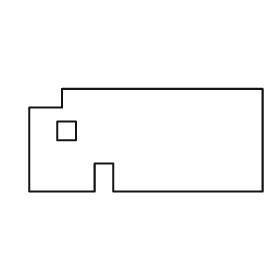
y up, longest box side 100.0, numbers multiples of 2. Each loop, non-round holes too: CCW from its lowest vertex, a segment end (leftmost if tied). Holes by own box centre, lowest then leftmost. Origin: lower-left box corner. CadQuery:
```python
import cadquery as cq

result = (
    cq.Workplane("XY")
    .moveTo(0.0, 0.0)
    .lineTo(28.0, 0.0)
    .lineTo(28.0, 12.0)
    .lineTo(36.0, 12.0)
    .lineTo(36.0, 0.0)
    .lineTo(100.0, 0.0)
    .lineTo(100.0, 44.0)
    .lineTo(14.0, 44.0)
    .lineTo(14.0, 36.0)
    .lineTo(0.0, 36.0)
    .close()
    .moveTo(12.0, 22.0)
    .lineTo(20.0, 22.0)
    .lineTo(20.0, 30.0)
    .lineTo(12.0, 30.0)
    .close()
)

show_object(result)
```